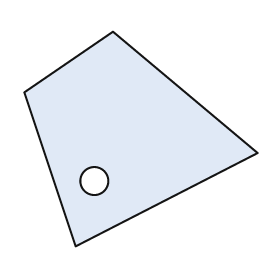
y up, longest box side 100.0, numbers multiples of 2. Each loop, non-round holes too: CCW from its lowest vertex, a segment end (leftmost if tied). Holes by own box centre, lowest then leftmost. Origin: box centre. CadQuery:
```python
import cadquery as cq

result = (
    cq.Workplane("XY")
    .moveTo(-28.0, -46.0)
    .lineTo(50.0, -6.0)
    .lineTo(-12.0, 46.0)
    .lineTo(-50.0, 20.0)
    .close()
    .moveTo(-20.0, -18.0)
    .circle(6.0)
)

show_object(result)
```